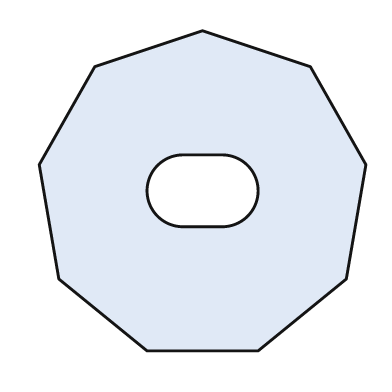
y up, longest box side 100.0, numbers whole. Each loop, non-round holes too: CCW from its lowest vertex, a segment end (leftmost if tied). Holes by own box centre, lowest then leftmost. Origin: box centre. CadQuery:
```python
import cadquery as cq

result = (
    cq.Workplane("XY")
    .moveTo(-17.0, -49.0)
    .lineTo(17.0, -49.0)
    .lineTo(44.0, -27.0)
    .lineTo(50.0, 8.0)
    .lineTo(33.0, 38.0)
    .lineTo(0.0, 49.0)
    .lineTo(-33.0, 38.0)
    .lineTo(-50.0, 8.0)
    .lineTo(-44.0, -27.0)
    .close()
    .moveTo(-6.0, -11.0)
    .lineTo(6.0, -11.0)
    .threePointArc((17.0, 0.0), (6.0, 11.0))
    .lineTo(-6.0, 11.0)
    .threePointArc((-17.0, 0.0), (-6.0, -11.0))
    .close()
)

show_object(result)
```